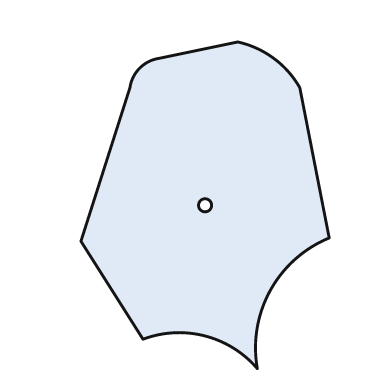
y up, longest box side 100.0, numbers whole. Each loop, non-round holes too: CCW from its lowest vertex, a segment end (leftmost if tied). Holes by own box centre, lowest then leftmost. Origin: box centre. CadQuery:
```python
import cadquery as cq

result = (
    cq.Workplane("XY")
    .moveTo(16.0, -50.0)
    .threePointArc((20.0, -26.0), (38.0, -10.0))
    .lineTo(29.0, 36.0)
    .threePointArc((21.0, 45.0), (10.0, 50.0))
    .lineTo(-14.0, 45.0)
    .threePointArc((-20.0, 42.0), (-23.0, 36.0))
    .lineTo(-38.0, -11.0)
    .lineTo(-19.0, -41.0)
    .threePointArc((0.0, -40.0), (16.0, -50.0))
    .close()
    .moveTo(0.0, 0.0)
    .circle(2.0)
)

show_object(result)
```